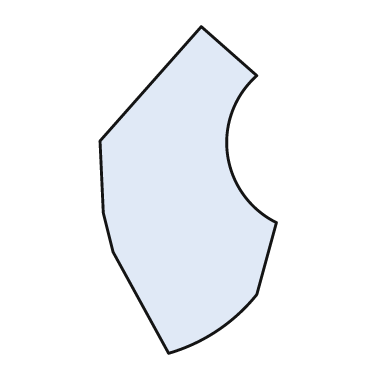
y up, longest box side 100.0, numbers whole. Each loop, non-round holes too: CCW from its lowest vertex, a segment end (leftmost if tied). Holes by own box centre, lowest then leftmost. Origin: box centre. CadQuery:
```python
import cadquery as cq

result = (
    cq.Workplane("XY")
    .moveTo(-6.0, -50.0)
    .threePointArc((9.0, -43.0), (21.0, -32.0))
    .lineTo(27.0, -10.0)
    .threePointArc((12.0, 11.0), (21.0, 35.0))
    .lineTo(4.0, 50.0)
    .lineTo(-27.0, 15.0)
    .lineTo(-26.0, -7.0)
    .lineTo(-23.0, -19.0)
    .close()
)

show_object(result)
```